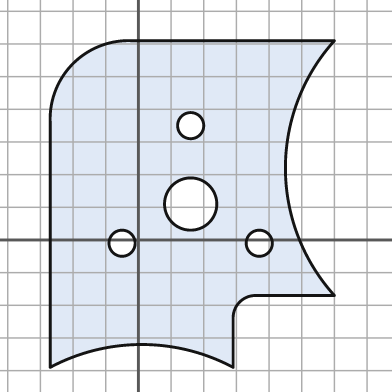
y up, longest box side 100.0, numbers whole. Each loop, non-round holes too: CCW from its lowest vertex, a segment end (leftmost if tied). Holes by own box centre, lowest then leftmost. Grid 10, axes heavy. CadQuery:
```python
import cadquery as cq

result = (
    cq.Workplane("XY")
    .moveTo(-27.0, -39.0)
    .threePointArc((1.0, -32.0), (29.0, -39.0))
    .lineTo(29.0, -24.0)
    .threePointArc((31.0, -19.0), (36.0, -17.0))
    .lineTo(60.0, -17.0)
    .threePointArc((45.0, 22.0), (60.0, 61.0))
    .lineTo(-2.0, 61.0)
    .threePointArc((-20.0, 54.0), (-27.0, 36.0))
    .close()
    .moveTo(-5.0, -1.0)
    .circle(4.0)
    .moveTo(37.0, -1.0)
    .circle(4.0)
    .moveTo(16.0, 11.0)
    .circle(8.0)
    .moveTo(16.0, 35.0)
    .circle(4.0)
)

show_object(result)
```